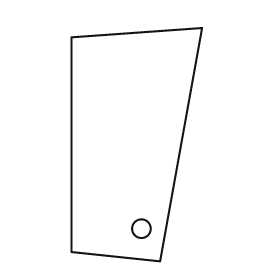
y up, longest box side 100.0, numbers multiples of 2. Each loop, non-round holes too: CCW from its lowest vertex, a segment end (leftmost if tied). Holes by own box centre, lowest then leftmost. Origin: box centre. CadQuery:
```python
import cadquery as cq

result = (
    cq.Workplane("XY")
    .moveTo(10.0, -50.0)
    .lineTo(28.0, 50.0)
    .lineTo(-28.0, 46.0)
    .lineTo(-28.0, -46.0)
    .close()
    .moveTo(2.0, -36.0)
    .circle(4.0)
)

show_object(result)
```